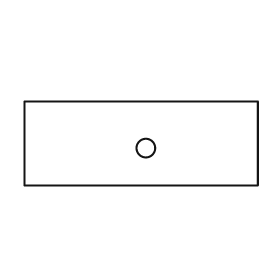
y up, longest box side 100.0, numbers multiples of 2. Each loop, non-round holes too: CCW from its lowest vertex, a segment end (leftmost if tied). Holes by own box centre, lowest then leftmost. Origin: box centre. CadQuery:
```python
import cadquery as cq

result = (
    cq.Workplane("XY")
    .moveTo(-50.0, -18.0)
    .lineTo(50.0, -18.0)
    .lineTo(50.0, 18.0)
    .lineTo(-50.0, 18.0)
    .close()
    .moveTo(2.0, -2.0)
    .circle(4.0)
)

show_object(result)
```